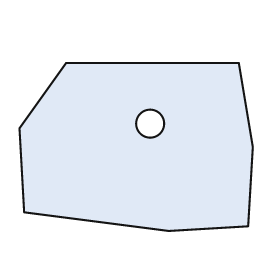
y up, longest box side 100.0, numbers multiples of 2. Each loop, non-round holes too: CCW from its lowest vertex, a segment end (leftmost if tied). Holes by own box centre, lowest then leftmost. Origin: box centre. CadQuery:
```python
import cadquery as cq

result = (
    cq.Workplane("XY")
    .moveTo(14.0, -36.0)
    .lineTo(48.0, -34.0)
    .lineTo(50.0, 0.0)
    .lineTo(44.0, 36.0)
    .lineTo(-30.0, 36.0)
    .lineTo(-50.0, 8.0)
    .lineTo(-48.0, -28.0)
    .close()
    .moveTo(6.0, 10.0)
    .circle(6.0)
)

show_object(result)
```